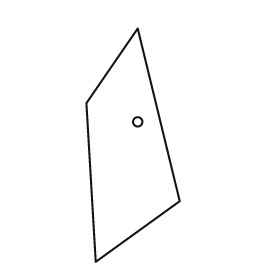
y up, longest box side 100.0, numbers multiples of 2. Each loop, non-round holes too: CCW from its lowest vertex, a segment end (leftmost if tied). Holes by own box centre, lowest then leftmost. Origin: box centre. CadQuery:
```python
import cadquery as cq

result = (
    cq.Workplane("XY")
    .moveTo(-16.0, -50.0)
    .lineTo(20.0, -24.0)
    .lineTo(2.0, 50.0)
    .lineTo(-20.0, 18.0)
    .close()
    .moveTo(2.0, 10.0)
    .circle(2.0)
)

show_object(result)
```